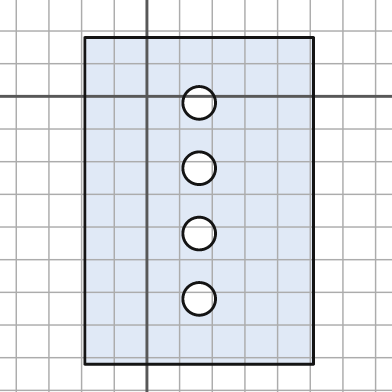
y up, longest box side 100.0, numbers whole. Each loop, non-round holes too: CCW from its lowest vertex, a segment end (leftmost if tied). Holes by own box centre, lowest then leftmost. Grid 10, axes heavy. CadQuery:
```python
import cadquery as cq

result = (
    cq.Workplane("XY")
    .moveTo(-19.0, -82.0)
    .lineTo(51.0, -82.0)
    .lineTo(51.0, 18.0)
    .lineTo(-19.0, 18.0)
    .close()
    .moveTo(16.0, -62.0)
    .circle(5.0)
    .moveTo(16.0, -42.0)
    .circle(5.0)
    .moveTo(16.0, -22.0)
    .circle(5.0)
    .moveTo(16.0, -2.0)
    .circle(5.0)
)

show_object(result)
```